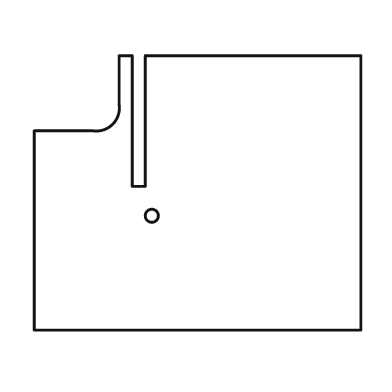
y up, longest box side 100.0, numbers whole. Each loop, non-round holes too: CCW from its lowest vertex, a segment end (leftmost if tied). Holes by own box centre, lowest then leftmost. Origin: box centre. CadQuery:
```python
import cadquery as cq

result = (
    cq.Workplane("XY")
    .moveTo(-50.0, -42.0)
    .lineTo(50.0, -42.0)
    .lineTo(50.0, 42.0)
    .lineTo(-16.0, 42.0)
    .lineTo(-16.0, 2.0)
    .lineTo(-20.0, 2.0)
    .lineTo(-20.0, 42.0)
    .lineTo(-24.0, 42.0)
    .lineTo(-24.0, 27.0)
    .threePointArc((-26.0, 21.0), (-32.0, 19.0))
    .lineTo(-50.0, 19.0)
    .close()
    .moveTo(-14.0, -7.0)
    .circle(2.0)
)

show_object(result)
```